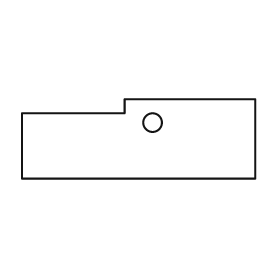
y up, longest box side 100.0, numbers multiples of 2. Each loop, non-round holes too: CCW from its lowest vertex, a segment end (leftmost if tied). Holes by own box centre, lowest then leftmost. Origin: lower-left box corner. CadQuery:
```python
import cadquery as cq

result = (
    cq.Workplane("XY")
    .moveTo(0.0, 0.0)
    .lineTo(100.0, 0.0)
    .lineTo(100.0, 34.0)
    .lineTo(44.0, 34.0)
    .lineTo(44.0, 28.0)
    .lineTo(0.0, 28.0)
    .close()
    .moveTo(56.0, 24.0)
    .circle(4.0)
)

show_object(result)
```